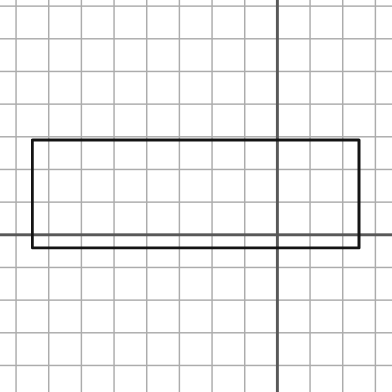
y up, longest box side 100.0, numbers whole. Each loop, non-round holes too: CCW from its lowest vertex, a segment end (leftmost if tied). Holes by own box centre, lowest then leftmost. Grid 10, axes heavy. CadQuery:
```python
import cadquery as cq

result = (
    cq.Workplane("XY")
    .moveTo(-75.0, -4.0)
    .lineTo(25.0, -4.0)
    .lineTo(25.0, 29.0)
    .lineTo(-75.0, 29.0)
    .close()
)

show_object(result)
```